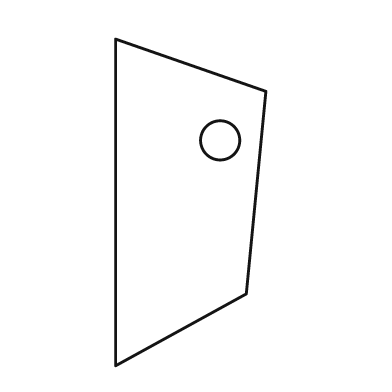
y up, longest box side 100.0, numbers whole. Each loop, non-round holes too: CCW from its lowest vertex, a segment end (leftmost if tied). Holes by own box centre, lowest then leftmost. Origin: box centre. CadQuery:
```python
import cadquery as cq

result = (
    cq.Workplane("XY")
    .moveTo(-23.0, -50.0)
    .lineTo(17.0, -28.0)
    .lineTo(23.0, 34.0)
    .lineTo(-23.0, 50.0)
    .close()
    .moveTo(9.0, 19.0)
    .circle(6.0)
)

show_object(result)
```